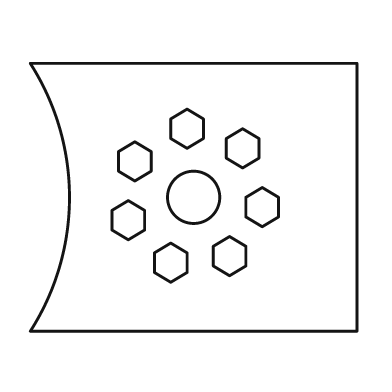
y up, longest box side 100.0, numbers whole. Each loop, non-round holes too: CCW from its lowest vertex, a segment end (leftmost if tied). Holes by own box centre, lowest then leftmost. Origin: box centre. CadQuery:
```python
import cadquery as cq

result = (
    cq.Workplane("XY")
    .moveTo(-50.0, -41.0)
    .lineTo(50.0, -41.0)
    .lineTo(50.0, 41.0)
    .lineTo(-50.0, 41.0)
    .threePointArc((-38.0, 0.0), (-50.0, -41.0))
    .close()
    .moveTo(-7.0, -26.0)
    .lineTo(-2.0, -23.0)
    .lineTo(-2.0, -17.0)
    .lineTo(-7.0, -14.0)
    .lineTo(-12.0, -17.0)
    .lineTo(-12.0, -23.0)
    .close()
    .moveTo(11.0, -24.0)
    .lineTo(16.0, -21.0)
    .lineTo(16.0, -15.0)
    .lineTo(11.0, -12.0)
    .lineTo(6.0, -15.0)
    .lineTo(6.0, -21.0)
    .close()
    .moveTo(-20.0, -13.0)
    .lineTo(-15.0, -10.0)
    .lineTo(-15.0, -4.0)
    .lineTo(-20.0, -1.0)
    .lineTo(-25.0, -4.0)
    .lineTo(-25.0, -10.0)
    .close()
    .moveTo(21.0, -9.0)
    .lineTo(26.0, -6.0)
    .lineTo(26.0, 0.0)
    .lineTo(21.0, 3.0)
    .lineTo(16.0, 0.0)
    .lineTo(16.0, -6.0)
    .close()
    .moveTo(0.0, 0.0)
    .circle(8.0)
    .moveTo(-18.0, 5.0)
    .lineTo(-13.0, 8.0)
    .lineTo(-13.0, 14.0)
    .lineTo(-18.0, 17.0)
    .lineTo(-23.0, 14.0)
    .lineTo(-23.0, 8.0)
    .close()
    .moveTo(15.0, 9.0)
    .lineTo(20.0, 12.0)
    .lineTo(20.0, 18.0)
    .lineTo(15.0, 21.0)
    .lineTo(10.0, 18.0)
    .lineTo(10.0, 12.0)
    .close()
    .moveTo(-2.0, 15.0)
    .lineTo(3.0, 18.0)
    .lineTo(3.0, 24.0)
    .lineTo(-2.0, 27.0)
    .lineTo(-7.0, 24.0)
    .lineTo(-7.0, 18.0)
    .close()
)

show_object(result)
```